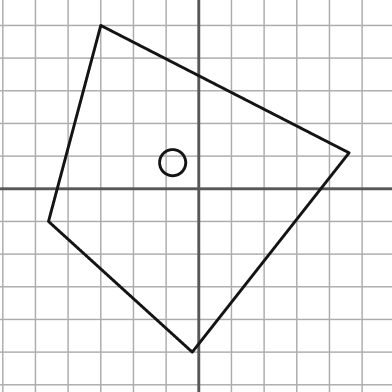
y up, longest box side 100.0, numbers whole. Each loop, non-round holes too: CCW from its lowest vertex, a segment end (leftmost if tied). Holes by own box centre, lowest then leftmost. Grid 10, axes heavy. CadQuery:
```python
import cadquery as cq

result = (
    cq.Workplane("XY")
    .moveTo(-2.0, -50.0)
    .lineTo(46.0, 11.0)
    .lineTo(-30.0, 50.0)
    .lineTo(-46.0, -10.0)
    .close()
    .moveTo(-8.0, 8.0)
    .circle(4.0)
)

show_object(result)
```